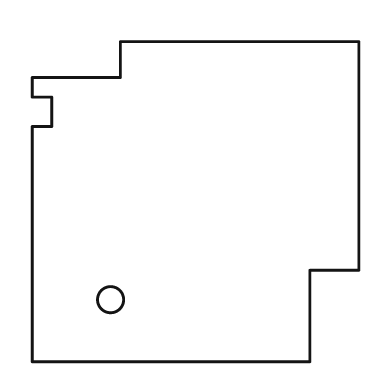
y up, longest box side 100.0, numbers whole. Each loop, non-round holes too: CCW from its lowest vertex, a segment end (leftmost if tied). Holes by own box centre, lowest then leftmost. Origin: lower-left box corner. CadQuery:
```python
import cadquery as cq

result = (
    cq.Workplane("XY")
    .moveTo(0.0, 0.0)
    .lineTo(85.0, 0.0)
    .lineTo(85.0, 28.0)
    .lineTo(100.0, 28.0)
    .lineTo(100.0, 98.0)
    .lineTo(27.0, 98.0)
    .lineTo(27.0, 87.0)
    .lineTo(0.0, 87.0)
    .lineTo(0.0, 81.0)
    .lineTo(6.0, 81.0)
    .lineTo(6.0, 72.0)
    .lineTo(0.0, 72.0)
    .close()
    .moveTo(24.0, 19.0)
    .circle(4.0)
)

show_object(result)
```